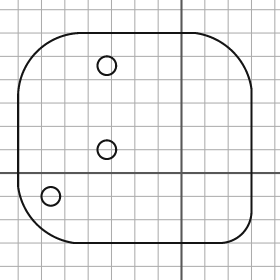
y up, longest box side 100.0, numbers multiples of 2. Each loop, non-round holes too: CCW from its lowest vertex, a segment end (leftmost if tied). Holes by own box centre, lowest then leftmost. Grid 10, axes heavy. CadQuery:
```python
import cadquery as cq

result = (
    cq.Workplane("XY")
    .moveTo(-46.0, -30.0)
    .lineTo(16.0, -30.0)
    .threePointArc((26.0, -26.0), (30.0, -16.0))
    .lineTo(30.0, 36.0)
    .threePointArc((22.0, 52.0), (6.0, 60.0))
    .lineTo(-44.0, 60.0)
    .threePointArc((-62.0, 52.0), (-70.0, 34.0))
    .lineTo(-70.0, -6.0)
    .threePointArc((-62.0, -22.0), (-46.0, -30.0))
    .close()
    .moveTo(-56.0, -10.0)
    .circle(4.0)
    .moveTo(-32.0, 10.0)
    .circle(4.0)
    .moveTo(-32.0, 46.0)
    .circle(4.0)
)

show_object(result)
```